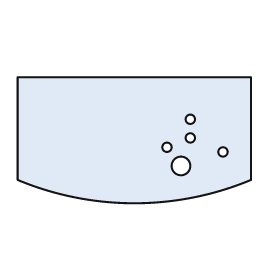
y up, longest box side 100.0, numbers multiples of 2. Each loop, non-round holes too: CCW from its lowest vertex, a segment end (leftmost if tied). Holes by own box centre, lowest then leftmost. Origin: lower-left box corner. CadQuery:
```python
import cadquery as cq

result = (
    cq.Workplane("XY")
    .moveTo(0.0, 10.0)
    .threePointArc((50.0, 0.0), (100.0, 10.0))
    .lineTo(100.0, 54.0)
    .lineTo(0.0, 54.0)
    .close()
    .moveTo(70.0, 16.0)
    .circle(4.0)
    .moveTo(88.0, 22.0)
    .circle(2.0)
    .moveTo(64.0, 24.0)
    .circle(2.0)
    .moveTo(74.0, 28.0)
    .circle(2.0)
    .moveTo(74.0, 36.0)
    .circle(2.0)
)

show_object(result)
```